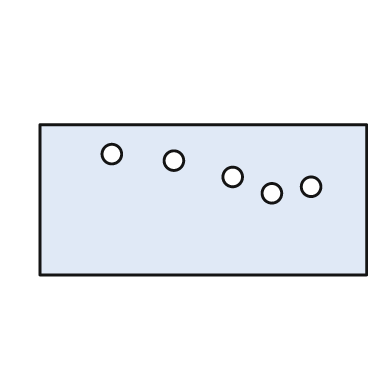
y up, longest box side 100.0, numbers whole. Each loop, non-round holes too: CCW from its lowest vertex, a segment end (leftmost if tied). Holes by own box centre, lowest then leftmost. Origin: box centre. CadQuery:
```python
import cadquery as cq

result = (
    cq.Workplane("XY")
    .moveTo(-50.0, -23.0)
    .lineTo(50.0, -23.0)
    .lineTo(50.0, 23.0)
    .lineTo(-50.0, 23.0)
    .close()
    .moveTo(21.0, 2.0)
    .circle(3.0)
    .moveTo(33.0, 4.0)
    .circle(3.0)
    .moveTo(9.0, 7.0)
    .circle(3.0)
    .moveTo(-9.0, 12.0)
    .circle(3.0)
    .moveTo(-28.0, 14.0)
    .circle(3.0)
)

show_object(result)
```